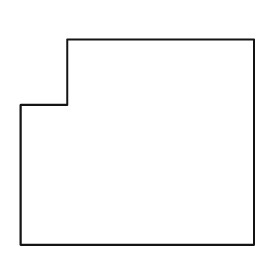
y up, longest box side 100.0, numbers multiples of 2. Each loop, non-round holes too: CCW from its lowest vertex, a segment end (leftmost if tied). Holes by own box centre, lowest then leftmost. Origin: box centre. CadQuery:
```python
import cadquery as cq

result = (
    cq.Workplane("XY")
    .moveTo(-50.0, -44.0)
    .lineTo(50.0, -44.0)
    .lineTo(50.0, 44.0)
    .lineTo(-30.0, 44.0)
    .lineTo(-30.0, 16.0)
    .lineTo(-50.0, 16.0)
    .close()
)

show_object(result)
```